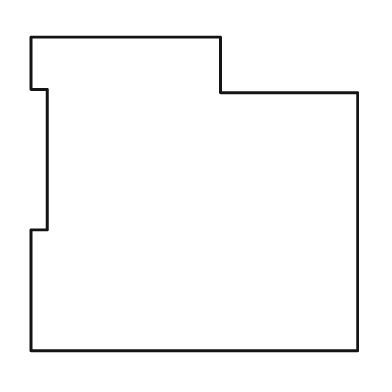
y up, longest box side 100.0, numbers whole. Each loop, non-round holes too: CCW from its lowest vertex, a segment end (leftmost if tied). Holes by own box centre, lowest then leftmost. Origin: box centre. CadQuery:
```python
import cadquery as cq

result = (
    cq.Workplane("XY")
    .moveTo(-50.0, -48.0)
    .lineTo(50.0, -48.0)
    .lineTo(50.0, 31.0)
    .lineTo(8.0, 31.0)
    .lineTo(8.0, 48.0)
    .lineTo(-50.0, 48.0)
    .lineTo(-50.0, 32.0)
    .lineTo(-45.0, 32.0)
    .lineTo(-45.0, -11.0)
    .lineTo(-50.0, -11.0)
    .close()
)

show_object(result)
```